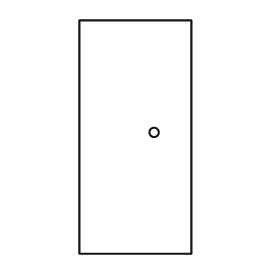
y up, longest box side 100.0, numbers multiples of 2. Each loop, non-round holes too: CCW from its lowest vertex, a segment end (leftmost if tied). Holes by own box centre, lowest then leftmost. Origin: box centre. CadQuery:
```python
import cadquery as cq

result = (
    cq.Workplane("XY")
    .moveTo(-24.0, -50.0)
    .lineTo(24.0, -50.0)
    .lineTo(24.0, 50.0)
    .lineTo(-24.0, 50.0)
    .close()
    .moveTo(8.0, 2.0)
    .circle(2.0)
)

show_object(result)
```